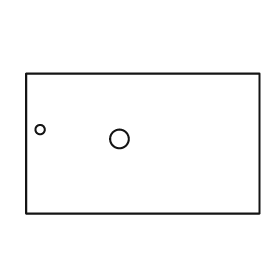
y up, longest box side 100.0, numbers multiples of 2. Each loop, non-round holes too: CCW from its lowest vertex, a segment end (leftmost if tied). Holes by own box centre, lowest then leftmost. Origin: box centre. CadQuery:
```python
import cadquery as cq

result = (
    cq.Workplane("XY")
    .moveTo(-50.0, -30.0)
    .lineTo(50.0, -30.0)
    .lineTo(50.0, 30.0)
    .lineTo(-50.0, 30.0)
    .close()
    .moveTo(-10.0, 2.0)
    .circle(4.0)
    .moveTo(-44.0, 6.0)
    .circle(2.0)
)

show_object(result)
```